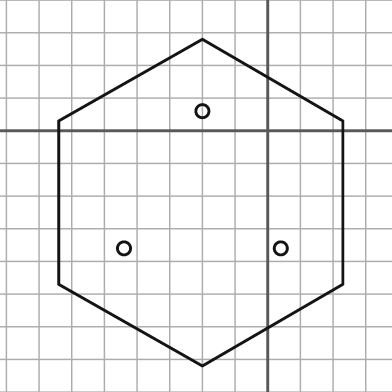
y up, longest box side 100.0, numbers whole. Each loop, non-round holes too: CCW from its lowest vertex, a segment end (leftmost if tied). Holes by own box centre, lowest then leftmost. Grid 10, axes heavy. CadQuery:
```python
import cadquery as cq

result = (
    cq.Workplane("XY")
    .moveTo(-20.0, -72.0)
    .lineTo(23.0, -47.0)
    .lineTo(23.0, 3.0)
    .lineTo(-20.0, 28.0)
    .lineTo(-64.0, 3.0)
    .lineTo(-64.0, -47.0)
    .close()
    .moveTo(-44.0, -36.0)
    .circle(2.0)
    .moveTo(4.0, -36.0)
    .circle(2.0)
    .moveTo(-20.0, 6.0)
    .circle(2.0)
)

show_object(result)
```